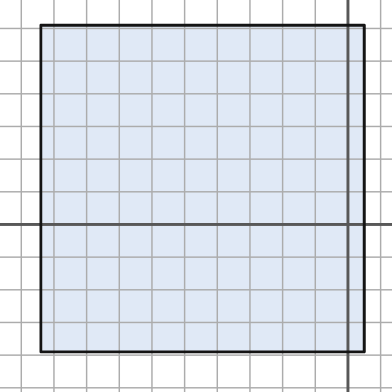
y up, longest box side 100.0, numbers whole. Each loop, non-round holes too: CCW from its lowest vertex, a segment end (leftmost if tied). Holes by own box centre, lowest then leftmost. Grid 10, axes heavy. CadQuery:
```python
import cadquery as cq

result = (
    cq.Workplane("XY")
    .moveTo(-94.0, -39.0)
    .lineTo(5.0, -39.0)
    .lineTo(5.0, 61.0)
    .lineTo(-94.0, 61.0)
    .close()
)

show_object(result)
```